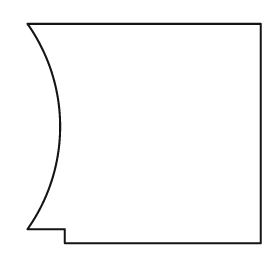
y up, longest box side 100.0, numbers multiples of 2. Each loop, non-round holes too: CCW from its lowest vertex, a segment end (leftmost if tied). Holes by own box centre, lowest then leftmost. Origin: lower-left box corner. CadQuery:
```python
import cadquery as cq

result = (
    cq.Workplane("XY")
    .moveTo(16.0, 0.0)
    .lineTo(100.0, 0.0)
    .lineTo(100.0, 94.0)
    .lineTo(0.0, 94.0)
    .threePointArc((14.0, 50.0), (0.0, 6.0))
    .lineTo(16.0, 6.0)
    .close()
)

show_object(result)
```